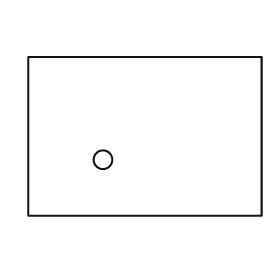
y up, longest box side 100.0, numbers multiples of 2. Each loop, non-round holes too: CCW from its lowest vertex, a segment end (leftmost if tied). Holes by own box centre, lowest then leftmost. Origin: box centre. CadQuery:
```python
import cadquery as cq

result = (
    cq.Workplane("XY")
    .moveTo(-50.0, -34.0)
    .lineTo(50.0, -34.0)
    .lineTo(50.0, 34.0)
    .lineTo(-50.0, 34.0)
    .close()
    .moveTo(-18.0, -10.0)
    .circle(4.0)
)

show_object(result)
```